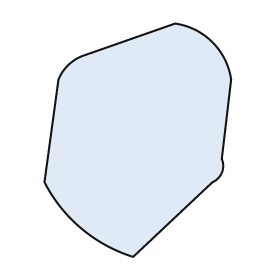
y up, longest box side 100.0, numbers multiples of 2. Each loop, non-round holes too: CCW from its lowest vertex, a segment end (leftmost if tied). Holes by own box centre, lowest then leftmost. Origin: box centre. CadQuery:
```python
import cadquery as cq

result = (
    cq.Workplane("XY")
    .moveTo(-2.0, -50.0)
    .lineTo(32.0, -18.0)
    .threePointArc((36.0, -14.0), (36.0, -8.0))
    .lineTo(40.0, 26.0)
    .threePointArc((32.0, 42.0), (16.0, 50.0))
    .lineTo(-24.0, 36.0)
    .threePointArc((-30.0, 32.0), (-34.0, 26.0))
    .lineTo(-40.0, -18.0)
    .threePointArc((-24.0, -38.0), (-2.0, -50.0))
    .close()
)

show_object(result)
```